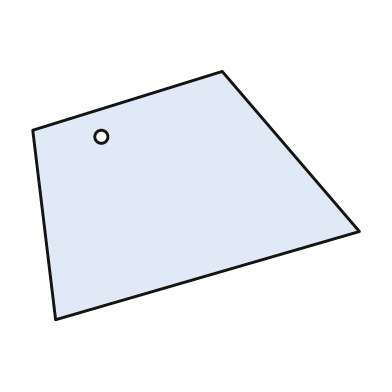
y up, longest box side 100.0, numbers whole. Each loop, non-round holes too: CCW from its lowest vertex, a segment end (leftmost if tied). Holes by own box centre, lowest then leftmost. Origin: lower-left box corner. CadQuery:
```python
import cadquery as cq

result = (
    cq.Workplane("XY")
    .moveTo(7.0, 0.0)
    .lineTo(100.0, 27.0)
    .lineTo(58.0, 76.0)
    .lineTo(0.0, 58.0)
    .close()
    .moveTo(21.0, 56.0)
    .circle(2.0)
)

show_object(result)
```